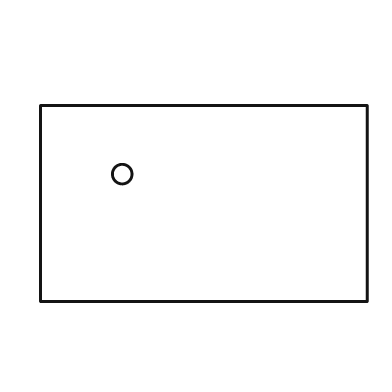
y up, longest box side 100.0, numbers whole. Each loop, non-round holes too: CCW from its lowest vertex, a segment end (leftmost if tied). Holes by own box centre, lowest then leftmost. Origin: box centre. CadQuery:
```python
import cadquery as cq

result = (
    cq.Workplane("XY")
    .moveTo(-50.0, -30.0)
    .lineTo(50.0, -30.0)
    .lineTo(50.0, 30.0)
    .lineTo(-50.0, 30.0)
    .close()
    .moveTo(-25.0, 9.0)
    .circle(3.0)
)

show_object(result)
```